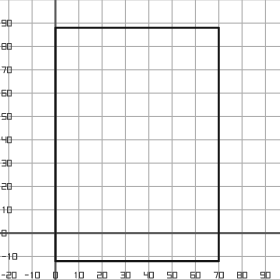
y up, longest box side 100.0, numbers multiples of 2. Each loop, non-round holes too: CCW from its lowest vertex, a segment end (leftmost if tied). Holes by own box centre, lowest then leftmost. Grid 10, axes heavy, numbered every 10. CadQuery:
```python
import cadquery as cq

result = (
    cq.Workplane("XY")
    .moveTo(0.0, -12.0)
    .lineTo(70.0, -12.0)
    .lineTo(70.0, 88.0)
    .lineTo(0.0, 88.0)
    .close()
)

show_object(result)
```